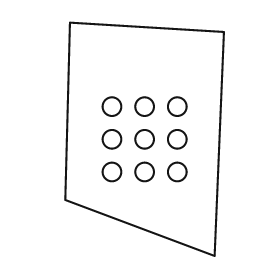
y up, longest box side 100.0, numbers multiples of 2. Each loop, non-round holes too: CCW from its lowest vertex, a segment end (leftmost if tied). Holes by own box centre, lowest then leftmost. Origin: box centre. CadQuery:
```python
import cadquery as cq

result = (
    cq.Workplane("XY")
    .moveTo(30.0, -50.0)
    .lineTo(34.0, 46.0)
    .lineTo(-32.0, 50.0)
    .lineTo(-34.0, -26.0)
    .close()
    .moveTo(-14.0, -14.0)
    .circle(4.0)
    .moveTo(0.0, -14.0)
    .circle(4.0)
    .moveTo(14.0, -14.0)
    .circle(4.0)
    .moveTo(-14.0, 0.0)
    .circle(4.0)
    .moveTo(0.0, 0.0)
    .circle(4.0)
    .moveTo(14.0, 0.0)
    .circle(4.0)
    .moveTo(-14.0, 14.0)
    .circle(4.0)
    .moveTo(0.0, 14.0)
    .circle(4.0)
    .moveTo(14.0, 14.0)
    .circle(4.0)
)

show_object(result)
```